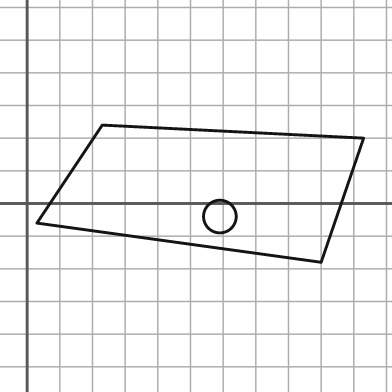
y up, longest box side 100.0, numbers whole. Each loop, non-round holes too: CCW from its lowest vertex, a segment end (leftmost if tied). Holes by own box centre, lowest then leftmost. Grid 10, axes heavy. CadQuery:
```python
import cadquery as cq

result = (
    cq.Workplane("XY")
    .moveTo(90.0, -18.0)
    .lineTo(103.0, 20.0)
    .lineTo(23.0, 24.0)
    .lineTo(3.0, -6.0)
    .close()
    .moveTo(59.0, -4.0)
    .circle(5.0)
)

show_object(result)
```